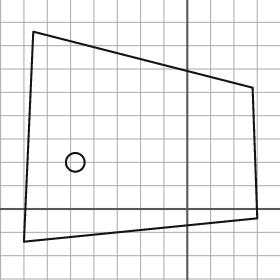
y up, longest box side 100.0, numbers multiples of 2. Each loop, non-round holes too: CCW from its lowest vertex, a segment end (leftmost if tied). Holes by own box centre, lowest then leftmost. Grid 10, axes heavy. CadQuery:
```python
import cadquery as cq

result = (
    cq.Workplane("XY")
    .moveTo(-70.0, -14.0)
    .lineTo(30.0, -4.0)
    .lineTo(28.0, 52.0)
    .lineTo(-66.0, 76.0)
    .close()
    .moveTo(-48.0, 20.0)
    .circle(4.0)
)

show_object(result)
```